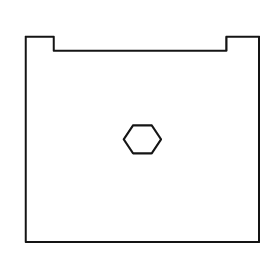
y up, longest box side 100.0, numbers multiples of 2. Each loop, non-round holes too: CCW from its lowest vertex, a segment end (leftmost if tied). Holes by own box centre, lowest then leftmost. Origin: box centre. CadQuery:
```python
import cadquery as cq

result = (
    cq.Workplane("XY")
    .moveTo(-50.0, -44.0)
    .lineTo(50.0, -44.0)
    .lineTo(50.0, 44.0)
    .lineTo(36.0, 44.0)
    .lineTo(36.0, 38.0)
    .lineTo(-38.0, 38.0)
    .lineTo(-38.0, 44.0)
    .lineTo(-50.0, 44.0)
    .close()
    .moveTo(-4.0, -6.0)
    .lineTo(4.0, -6.0)
    .lineTo(8.0, 0.0)
    .lineTo(4.0, 6.0)
    .lineTo(-4.0, 6.0)
    .lineTo(-8.0, 0.0)
    .close()
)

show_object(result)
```